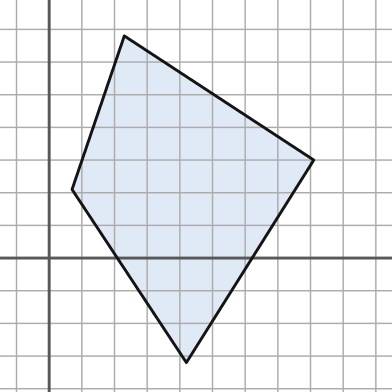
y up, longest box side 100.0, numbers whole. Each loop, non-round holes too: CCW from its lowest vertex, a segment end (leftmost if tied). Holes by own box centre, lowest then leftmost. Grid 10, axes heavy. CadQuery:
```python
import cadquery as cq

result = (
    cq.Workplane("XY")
    .moveTo(42.0, -32.0)
    .lineTo(81.0, 30.0)
    .lineTo(23.0, 68.0)
    .lineTo(7.0, 21.0)
    .close()
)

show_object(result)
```